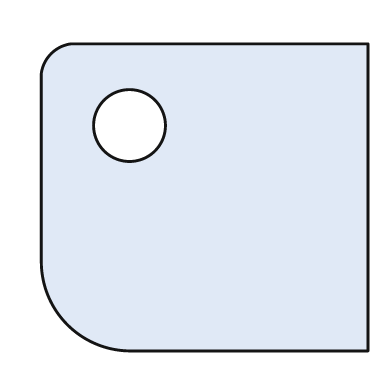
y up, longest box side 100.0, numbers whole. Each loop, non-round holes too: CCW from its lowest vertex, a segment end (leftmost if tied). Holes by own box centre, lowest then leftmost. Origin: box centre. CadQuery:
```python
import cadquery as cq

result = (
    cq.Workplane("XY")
    .moveTo(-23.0, -47.0)
    .lineTo(50.0, -47.0)
    .lineTo(50.0, 47.0)
    .lineTo(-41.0, 47.0)
    .threePointArc((-47.0, 44.0), (-50.0, 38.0))
    .lineTo(-50.0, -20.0)
    .threePointArc((-42.0, -39.0), (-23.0, -47.0))
    .close()
    .moveTo(-23.0, 22.0)
    .circle(11.0)
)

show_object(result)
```